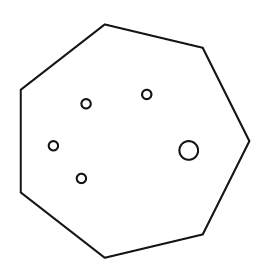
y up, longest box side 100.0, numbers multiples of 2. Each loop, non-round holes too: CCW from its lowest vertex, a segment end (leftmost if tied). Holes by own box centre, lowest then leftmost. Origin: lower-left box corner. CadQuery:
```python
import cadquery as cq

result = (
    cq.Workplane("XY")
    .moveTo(36.0, 0.0)
    .lineTo(78.0, 10.0)
    .lineTo(98.0, 50.0)
    .lineTo(78.0, 90.0)
    .lineTo(36.0, 100.0)
    .lineTo(0.0, 72.0)
    .lineTo(0.0, 28.0)
    .close()
    .moveTo(26.0, 34.0)
    .circle(2.0)
    .moveTo(72.0, 46.0)
    .circle(4.0)
    .moveTo(14.0, 48.0)
    .circle(2.0)
    .moveTo(28.0, 66.0)
    .circle(2.0)
    .moveTo(54.0, 70.0)
    .circle(2.0)
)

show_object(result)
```